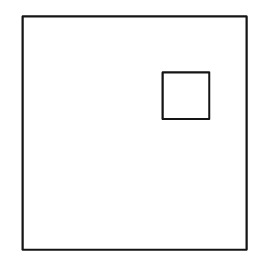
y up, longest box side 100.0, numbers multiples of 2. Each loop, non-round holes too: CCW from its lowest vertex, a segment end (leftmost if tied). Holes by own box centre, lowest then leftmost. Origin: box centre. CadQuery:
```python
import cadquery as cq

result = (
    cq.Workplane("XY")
    .moveTo(-48.0, -50.0)
    .lineTo(48.0, -50.0)
    .lineTo(48.0, 50.0)
    .lineTo(-48.0, 50.0)
    .close()
    .moveTo(12.0, 6.0)
    .lineTo(32.0, 6.0)
    .lineTo(32.0, 26.0)
    .lineTo(12.0, 26.0)
    .close()
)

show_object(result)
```